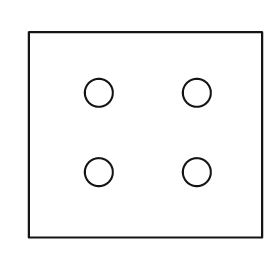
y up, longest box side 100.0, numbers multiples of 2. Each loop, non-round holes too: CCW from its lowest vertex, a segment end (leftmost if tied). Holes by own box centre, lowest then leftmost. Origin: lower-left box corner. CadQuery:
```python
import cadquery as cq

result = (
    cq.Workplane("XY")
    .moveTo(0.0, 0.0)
    .lineTo(100.0, 0.0)
    .lineTo(100.0, 88.0)
    .lineTo(0.0, 88.0)
    .close()
    .moveTo(30.0, 28.0)
    .circle(6.0)
    .moveTo(72.0, 28.0)
    .circle(6.0)
    .moveTo(30.0, 62.0)
    .circle(6.0)
    .moveTo(72.0, 62.0)
    .circle(6.0)
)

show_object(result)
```